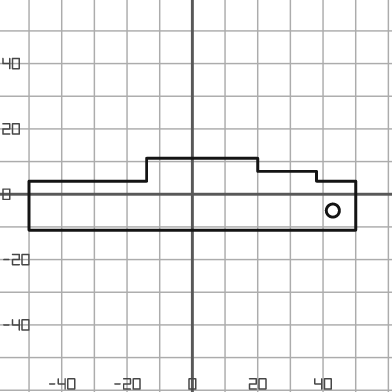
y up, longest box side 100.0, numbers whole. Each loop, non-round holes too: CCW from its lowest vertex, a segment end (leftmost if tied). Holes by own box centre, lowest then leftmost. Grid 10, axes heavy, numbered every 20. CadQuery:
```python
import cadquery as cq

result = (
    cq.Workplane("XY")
    .moveTo(-50.0, -11.0)
    .lineTo(50.0, -11.0)
    .lineTo(50.0, 4.0)
    .lineTo(38.0, 4.0)
    .lineTo(38.0, 7.0)
    .lineTo(20.0, 7.0)
    .lineTo(20.0, 11.0)
    .lineTo(-14.0, 11.0)
    .lineTo(-14.0, 4.0)
    .lineTo(-50.0, 4.0)
    .close()
    .moveTo(43.0, -5.0)
    .circle(2.0)
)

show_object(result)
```